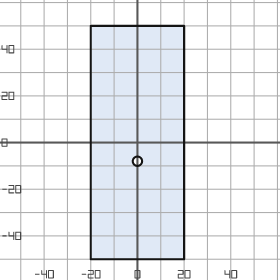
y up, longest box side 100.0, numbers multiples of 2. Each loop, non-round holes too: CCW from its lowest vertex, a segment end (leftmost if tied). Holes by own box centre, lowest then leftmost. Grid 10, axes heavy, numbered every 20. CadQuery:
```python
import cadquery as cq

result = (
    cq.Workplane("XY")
    .moveTo(-20.0, -50.0)
    .lineTo(20.0, -50.0)
    .lineTo(20.0, 50.0)
    .lineTo(-20.0, 50.0)
    .close()
    .moveTo(0.0, -8.0)
    .circle(2.0)
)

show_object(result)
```